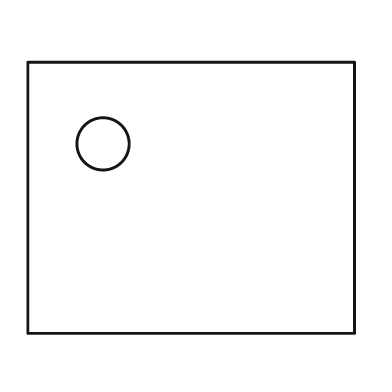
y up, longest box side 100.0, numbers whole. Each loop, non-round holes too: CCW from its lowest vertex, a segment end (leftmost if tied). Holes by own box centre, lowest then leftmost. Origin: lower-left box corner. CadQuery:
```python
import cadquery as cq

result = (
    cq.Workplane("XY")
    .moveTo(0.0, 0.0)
    .lineTo(100.0, 0.0)
    .lineTo(100.0, 83.0)
    .lineTo(0.0, 83.0)
    .close()
    .moveTo(23.0, 58.0)
    .circle(8.0)
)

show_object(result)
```